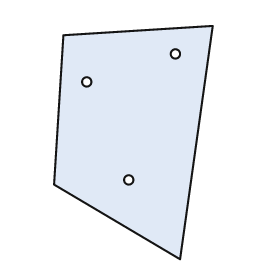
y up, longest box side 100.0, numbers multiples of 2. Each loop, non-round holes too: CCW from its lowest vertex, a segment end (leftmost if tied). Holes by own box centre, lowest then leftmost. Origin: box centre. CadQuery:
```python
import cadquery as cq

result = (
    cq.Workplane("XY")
    .moveTo(20.0, -50.0)
    .lineTo(34.0, 50.0)
    .lineTo(-30.0, 46.0)
    .lineTo(-34.0, -18.0)
    .close()
    .moveTo(-2.0, -16.0)
    .circle(2.0)
    .moveTo(-20.0, 26.0)
    .circle(2.0)
    .moveTo(18.0, 38.0)
    .circle(2.0)
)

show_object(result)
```